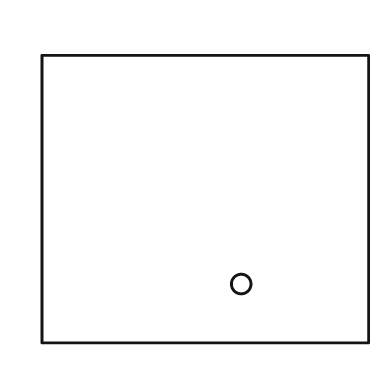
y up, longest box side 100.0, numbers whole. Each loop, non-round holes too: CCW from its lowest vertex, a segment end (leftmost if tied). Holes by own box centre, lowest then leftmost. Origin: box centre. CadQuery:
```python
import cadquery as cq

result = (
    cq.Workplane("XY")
    .moveTo(-50.0, -44.0)
    .lineTo(50.0, -44.0)
    .lineTo(50.0, 44.0)
    .lineTo(-50.0, 44.0)
    .close()
    .moveTo(11.0, -26.0)
    .circle(3.0)
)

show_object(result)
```